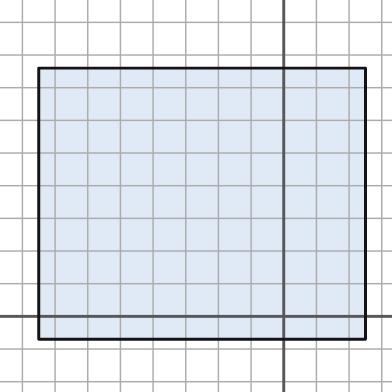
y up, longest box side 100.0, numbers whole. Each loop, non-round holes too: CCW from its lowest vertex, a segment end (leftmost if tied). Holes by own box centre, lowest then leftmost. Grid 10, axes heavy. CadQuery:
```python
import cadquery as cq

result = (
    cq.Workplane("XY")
    .moveTo(-75.0, -7.0)
    .lineTo(25.0, -7.0)
    .lineTo(25.0, 76.0)
    .lineTo(-75.0, 76.0)
    .close()
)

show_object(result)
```